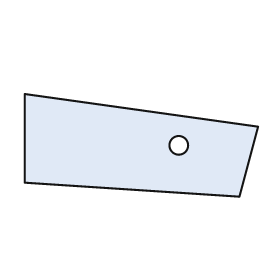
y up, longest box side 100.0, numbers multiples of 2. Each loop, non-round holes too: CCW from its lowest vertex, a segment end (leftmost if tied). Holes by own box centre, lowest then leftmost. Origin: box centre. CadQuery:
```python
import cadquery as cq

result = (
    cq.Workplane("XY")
    .moveTo(42.0, -22.0)
    .lineTo(50.0, 8.0)
    .lineTo(-50.0, 22.0)
    .lineTo(-50.0, -16.0)
    .close()
    .moveTo(16.0, 0.0)
    .circle(4.0)
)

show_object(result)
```